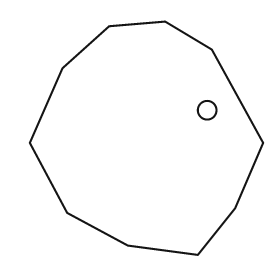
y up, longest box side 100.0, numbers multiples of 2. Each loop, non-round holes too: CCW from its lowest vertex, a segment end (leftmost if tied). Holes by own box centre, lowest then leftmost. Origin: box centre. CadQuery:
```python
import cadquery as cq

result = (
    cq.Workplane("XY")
    .moveTo(22.0, -50.0)
    .lineTo(38.0, -30.0)
    .lineTo(50.0, -2.0)
    .lineTo(28.0, 38.0)
    .lineTo(8.0, 50.0)
    .lineTo(-16.0, 48.0)
    .lineTo(-36.0, 30.0)
    .lineTo(-50.0, -2.0)
    .lineTo(-34.0, -32.0)
    .lineTo(-8.0, -46.0)
    .close()
    .moveTo(26.0, 12.0)
    .circle(4.0)
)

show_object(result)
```